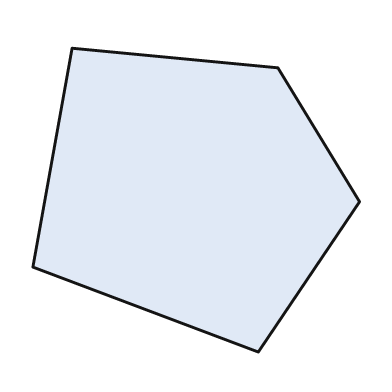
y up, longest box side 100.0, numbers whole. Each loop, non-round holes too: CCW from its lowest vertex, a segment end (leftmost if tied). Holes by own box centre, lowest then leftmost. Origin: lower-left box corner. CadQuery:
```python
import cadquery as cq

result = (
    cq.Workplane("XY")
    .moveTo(69.0, 0.0)
    .lineTo(100.0, 46.0)
    .lineTo(75.0, 87.0)
    .lineTo(12.0, 93.0)
    .lineTo(0.0, 26.0)
    .close()
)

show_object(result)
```